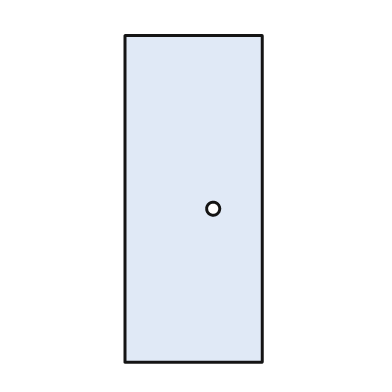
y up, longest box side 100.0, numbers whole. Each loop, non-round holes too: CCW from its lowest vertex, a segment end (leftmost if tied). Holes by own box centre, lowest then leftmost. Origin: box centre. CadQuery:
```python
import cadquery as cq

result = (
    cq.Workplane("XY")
    .moveTo(-21.0, -50.0)
    .lineTo(21.0, -50.0)
    .lineTo(21.0, 50.0)
    .lineTo(-21.0, 50.0)
    .close()
    .moveTo(6.0, -3.0)
    .circle(2.0)
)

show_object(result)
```